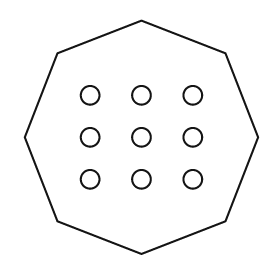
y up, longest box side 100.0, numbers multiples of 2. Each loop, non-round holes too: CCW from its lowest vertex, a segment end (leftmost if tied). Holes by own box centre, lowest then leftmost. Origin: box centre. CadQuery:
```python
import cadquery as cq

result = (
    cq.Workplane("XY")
    .moveTo(0.0, -50.0)
    .lineTo(36.0, -36.0)
    .lineTo(50.0, 0.0)
    .lineTo(36.0, 36.0)
    .lineTo(0.0, 50.0)
    .lineTo(-36.0, 36.0)
    .lineTo(-50.0, 0.0)
    .lineTo(-36.0, -36.0)
    .close()
    .moveTo(-22.0, -18.0)
    .circle(4.0)
    .moveTo(0.0, -18.0)
    .circle(4.0)
    .moveTo(22.0, -18.0)
    .circle(4.0)
    .moveTo(-22.0, 0.0)
    .circle(4.0)
    .moveTo(0.0, 0.0)
    .circle(4.0)
    .moveTo(22.0, 0.0)
    .circle(4.0)
    .moveTo(-22.0, 18.0)
    .circle(4.0)
    .moveTo(0.0, 18.0)
    .circle(4.0)
    .moveTo(22.0, 18.0)
    .circle(4.0)
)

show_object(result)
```